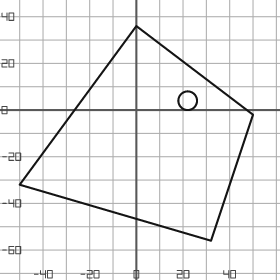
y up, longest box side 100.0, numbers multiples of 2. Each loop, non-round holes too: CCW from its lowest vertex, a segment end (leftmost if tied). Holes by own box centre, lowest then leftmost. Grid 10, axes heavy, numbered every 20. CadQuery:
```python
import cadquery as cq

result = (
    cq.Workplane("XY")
    .moveTo(32.0, -56.0)
    .lineTo(50.0, -2.0)
    .lineTo(0.0, 36.0)
    .lineTo(-50.0, -32.0)
    .close()
    .moveTo(22.0, 4.0)
    .circle(4.0)
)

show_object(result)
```